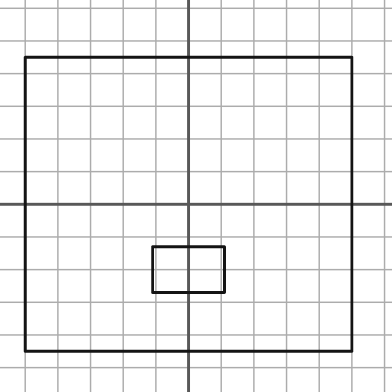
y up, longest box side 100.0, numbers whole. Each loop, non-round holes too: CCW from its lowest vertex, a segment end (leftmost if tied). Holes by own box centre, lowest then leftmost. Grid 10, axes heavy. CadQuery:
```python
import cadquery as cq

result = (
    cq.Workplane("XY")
    .moveTo(-50.0, -45.0)
    .lineTo(50.0, -45.0)
    .lineTo(50.0, 45.0)
    .lineTo(-50.0, 45.0)
    .close()
    .moveTo(-11.0, -27.0)
    .lineTo(11.0, -27.0)
    .lineTo(11.0, -13.0)
    .lineTo(-11.0, -13.0)
    .close()
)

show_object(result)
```